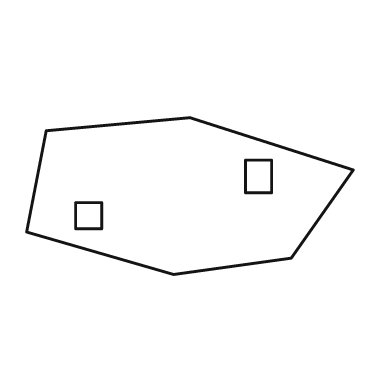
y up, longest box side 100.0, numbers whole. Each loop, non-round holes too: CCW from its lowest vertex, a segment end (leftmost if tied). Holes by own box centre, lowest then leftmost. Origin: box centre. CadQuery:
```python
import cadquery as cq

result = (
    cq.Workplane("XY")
    .moveTo(-5.0, -24.0)
    .lineTo(31.0, -19.0)
    .lineTo(50.0, 8.0)
    .lineTo(0.0, 24.0)
    .lineTo(-44.0, 20.0)
    .lineTo(-50.0, -11.0)
    .close()
    .moveTo(-35.0, -10.0)
    .lineTo(-27.0, -10.0)
    .lineTo(-27.0, -2.0)
    .lineTo(-35.0, -2.0)
    .close()
    .moveTo(17.0, 1.0)
    .lineTo(25.0, 1.0)
    .lineTo(25.0, 11.0)
    .lineTo(17.0, 11.0)
    .close()
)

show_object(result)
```